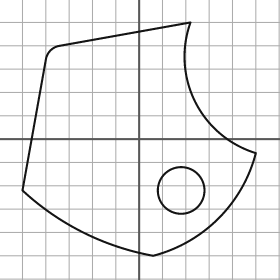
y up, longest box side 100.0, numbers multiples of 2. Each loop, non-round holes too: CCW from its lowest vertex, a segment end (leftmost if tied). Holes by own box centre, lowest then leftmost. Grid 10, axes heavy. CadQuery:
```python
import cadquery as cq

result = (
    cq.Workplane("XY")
    .moveTo(6.0, -50.0)
    .threePointArc((34.0, -34.0), (50.0, -6.0))
    .threePointArc((24.0, 16.0), (22.0, 50.0))
    .lineTo(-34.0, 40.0)
    .threePointArc((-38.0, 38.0), (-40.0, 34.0))
    .lineTo(-50.0, -22.0)
    .threePointArc((-24.0, -40.0), (6.0, -50.0))
    .close()
    .moveTo(18.0, -22.0)
    .circle(10.0)
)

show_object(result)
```